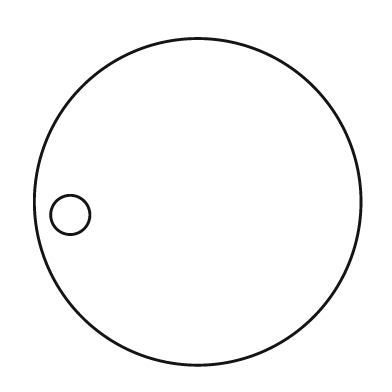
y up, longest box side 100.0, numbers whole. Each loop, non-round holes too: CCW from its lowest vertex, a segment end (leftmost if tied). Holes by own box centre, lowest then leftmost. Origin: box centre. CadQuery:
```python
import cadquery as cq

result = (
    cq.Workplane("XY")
    .moveTo(0.0, 0.0)
    .circle(50.0)
    .moveTo(-39.0, -4.0)
    .circle(6.0)
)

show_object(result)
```